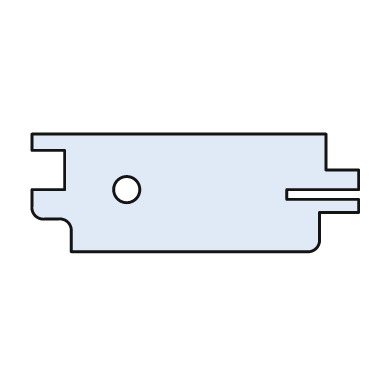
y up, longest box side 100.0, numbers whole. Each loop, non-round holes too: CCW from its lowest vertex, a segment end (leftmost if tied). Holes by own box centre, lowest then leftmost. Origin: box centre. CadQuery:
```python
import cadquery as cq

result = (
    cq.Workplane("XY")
    .moveTo(-38.0, -18.0)
    .lineTo(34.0, -18.0)
    .threePointArc((37.0, -17.0), (38.0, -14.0))
    .lineTo(38.0, -6.0)
    .lineTo(50.0, -6.0)
    .lineTo(50.0, -2.0)
    .lineTo(28.0, -2.0)
    .lineTo(28.0, 1.0)
    .lineTo(50.0, 1.0)
    .lineTo(50.0, 7.0)
    .lineTo(40.0, 7.0)
    .lineTo(40.0, 18.0)
    .lineTo(-50.0, 18.0)
    .lineTo(-50.0, 13.0)
    .lineTo(-40.0, 13.0)
    .lineTo(-40.0, 1.0)
    .lineTo(-50.0, 1.0)
    .lineTo(-50.0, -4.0)
    .threePointArc((-49.0, -7.0), (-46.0, -8.0))
    .lineTo(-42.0, -8.0)
    .threePointArc((-39.0, -9.0), (-38.0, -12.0))
    .close()
    .moveTo(-21.0, 1.0)
    .circle(4.0)
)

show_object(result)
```